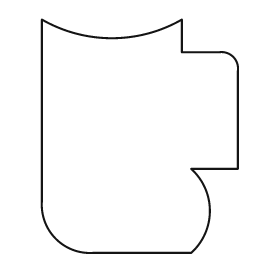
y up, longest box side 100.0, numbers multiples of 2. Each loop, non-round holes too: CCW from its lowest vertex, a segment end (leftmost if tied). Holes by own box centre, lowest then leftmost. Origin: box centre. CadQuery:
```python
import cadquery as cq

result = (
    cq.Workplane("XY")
    .moveTo(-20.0, -50.0)
    .lineTo(22.0, -50.0)
    .threePointArc((30.0, -32.0), (22.0, -14.0))
    .lineTo(42.0, -14.0)
    .lineTo(42.0, 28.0)
    .threePointArc((40.0, 34.0), (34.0, 36.0))
    .lineTo(18.0, 36.0)
    .lineTo(18.0, 50.0)
    .threePointArc((-12.0, 42.0), (-42.0, 50.0))
    .lineTo(-42.0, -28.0)
    .threePointArc((-36.0, -44.0), (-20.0, -50.0))
    .close()
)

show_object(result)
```